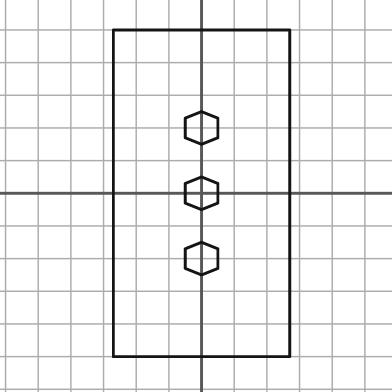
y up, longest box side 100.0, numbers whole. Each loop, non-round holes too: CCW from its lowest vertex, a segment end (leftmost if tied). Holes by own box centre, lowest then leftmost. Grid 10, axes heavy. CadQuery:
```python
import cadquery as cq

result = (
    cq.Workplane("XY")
    .moveTo(-27.0, -50.0)
    .lineTo(27.0, -50.0)
    .lineTo(27.0, 50.0)
    .lineTo(-27.0, 50.0)
    .close()
    .moveTo(0.0, -25.0)
    .lineTo(5.0, -23.0)
    .lineTo(5.0, -17.0)
    .lineTo(0.0, -15.0)
    .lineTo(-5.0, -17.0)
    .lineTo(-5.0, -23.0)
    .close()
    .moveTo(0.0, -5.0)
    .lineTo(5.0, -3.0)
    .lineTo(5.0, 3.0)
    .lineTo(0.0, 5.0)
    .lineTo(-5.0, 3.0)
    .lineTo(-5.0, -3.0)
    .close()
    .moveTo(0.0, 15.0)
    .lineTo(5.0, 17.0)
    .lineTo(5.0, 23.0)
    .lineTo(0.0, 25.0)
    .lineTo(-5.0, 23.0)
    .lineTo(-5.0, 17.0)
    .close()
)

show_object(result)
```